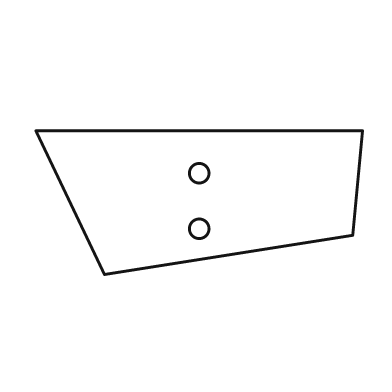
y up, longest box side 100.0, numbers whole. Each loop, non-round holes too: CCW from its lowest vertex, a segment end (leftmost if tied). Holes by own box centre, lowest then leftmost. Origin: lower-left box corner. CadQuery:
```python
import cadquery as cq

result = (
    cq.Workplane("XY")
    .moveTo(21.0, 0.0)
    .lineTo(97.0, 12.0)
    .lineTo(100.0, 44.0)
    .lineTo(0.0, 44.0)
    .close()
    .moveTo(50.0, 14.0)
    .circle(3.0)
    .moveTo(50.0, 31.0)
    .circle(3.0)
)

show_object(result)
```